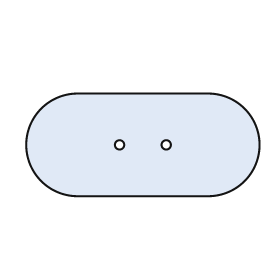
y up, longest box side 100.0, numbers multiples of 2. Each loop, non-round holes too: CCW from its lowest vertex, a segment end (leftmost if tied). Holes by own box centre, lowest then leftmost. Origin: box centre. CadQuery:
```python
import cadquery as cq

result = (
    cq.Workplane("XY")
    .moveTo(-28.0, -22.0)
    .lineTo(28.0, -22.0)
    .threePointArc((50.0, 0.0), (28.0, 22.0))
    .lineTo(-28.0, 22.0)
    .threePointArc((-50.0, 0.0), (-28.0, -22.0))
    .close()
    .moveTo(-10.0, 0.0)
    .circle(2.0)
    .moveTo(10.0, 0.0)
    .circle(2.0)
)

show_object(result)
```